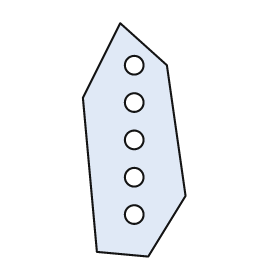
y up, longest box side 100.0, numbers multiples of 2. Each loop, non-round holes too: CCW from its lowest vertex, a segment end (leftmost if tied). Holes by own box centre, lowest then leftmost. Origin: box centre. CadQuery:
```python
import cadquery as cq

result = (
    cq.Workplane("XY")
    .moveTo(6.0, -50.0)
    .lineTo(22.0, -24.0)
    .lineTo(14.0, 32.0)
    .lineTo(-6.0, 50.0)
    .lineTo(-22.0, 18.0)
    .lineTo(-16.0, -48.0)
    .close()
    .moveTo(0.0, -32.0)
    .circle(4.0)
    .moveTo(0.0, -16.0)
    .circle(4.0)
    .moveTo(0.0, 0.0)
    .circle(4.0)
    .moveTo(0.0, 16.0)
    .circle(4.0)
    .moveTo(0.0, 32.0)
    .circle(4.0)
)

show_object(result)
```